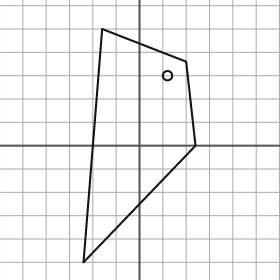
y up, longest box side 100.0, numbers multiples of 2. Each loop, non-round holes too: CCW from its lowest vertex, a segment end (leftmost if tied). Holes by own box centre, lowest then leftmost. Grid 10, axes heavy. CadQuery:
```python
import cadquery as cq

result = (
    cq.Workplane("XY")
    .moveTo(-24.0, -50.0)
    .lineTo(24.0, 0.0)
    .lineTo(20.0, 36.0)
    .lineTo(-16.0, 50.0)
    .close()
    .moveTo(12.0, 30.0)
    .circle(2.0)
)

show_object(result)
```